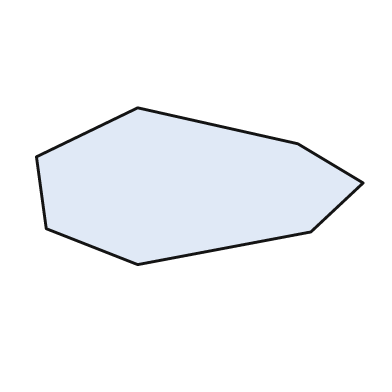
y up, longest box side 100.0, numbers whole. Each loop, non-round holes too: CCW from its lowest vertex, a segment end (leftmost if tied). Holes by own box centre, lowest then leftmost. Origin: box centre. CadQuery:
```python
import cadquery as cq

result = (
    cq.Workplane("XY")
    .moveTo(-19.0, -24.0)
    .lineTo(34.0, -14.0)
    .lineTo(50.0, 1.0)
    .lineTo(30.0, 13.0)
    .lineTo(-19.0, 24.0)
    .lineTo(-50.0, 9.0)
    .lineTo(-47.0, -13.0)
    .close()
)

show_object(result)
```